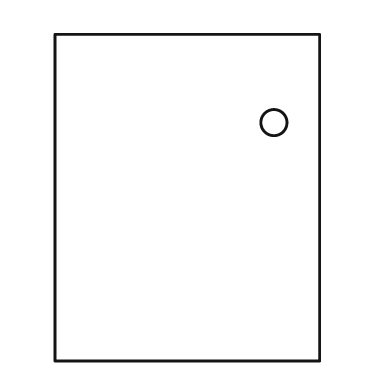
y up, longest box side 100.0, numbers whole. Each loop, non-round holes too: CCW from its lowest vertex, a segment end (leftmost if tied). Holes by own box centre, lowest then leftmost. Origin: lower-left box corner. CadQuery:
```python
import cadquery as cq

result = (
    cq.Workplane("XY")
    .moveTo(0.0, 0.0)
    .lineTo(81.0, 0.0)
    .lineTo(81.0, 100.0)
    .lineTo(0.0, 100.0)
    .close()
    .moveTo(67.0, 73.0)
    .circle(4.0)
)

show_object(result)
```